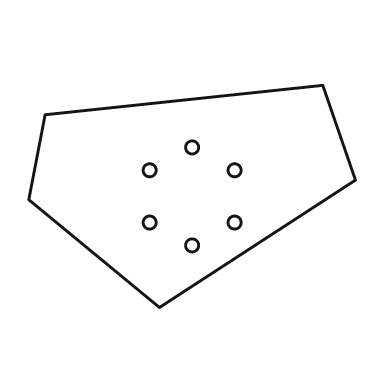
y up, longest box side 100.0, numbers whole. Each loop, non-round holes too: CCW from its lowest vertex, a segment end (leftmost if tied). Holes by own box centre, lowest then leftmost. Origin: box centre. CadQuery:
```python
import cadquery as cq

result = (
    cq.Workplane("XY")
    .moveTo(-10.0, -34.0)
    .lineTo(50.0, 5.0)
    .lineTo(40.0, 34.0)
    .lineTo(-45.0, 25.0)
    .lineTo(-50.0, -1.0)
    .close()
    .moveTo(0.0, -15.0)
    .circle(2.0)
    .moveTo(-13.0, -8.0)
    .circle(2.0)
    .moveTo(13.0, -8.0)
    .circle(2.0)
    .moveTo(-13.0, 8.0)
    .circle(2.0)
    .moveTo(13.0, 8.0)
    .circle(2.0)
    .moveTo(0.0, 15.0)
    .circle(2.0)
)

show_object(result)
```